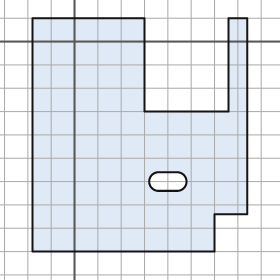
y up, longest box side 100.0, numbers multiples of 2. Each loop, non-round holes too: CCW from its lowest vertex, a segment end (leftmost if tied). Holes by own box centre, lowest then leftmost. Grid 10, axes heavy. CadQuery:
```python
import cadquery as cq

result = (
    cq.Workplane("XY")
    .moveTo(-18.0, -90.0)
    .lineTo(60.0, -90.0)
    .lineTo(60.0, -74.0)
    .lineTo(74.0, -74.0)
    .lineTo(74.0, 10.0)
    .lineTo(66.0, 10.0)
    .lineTo(66.0, -30.0)
    .lineTo(30.0, -30.0)
    .lineTo(30.0, 10.0)
    .lineTo(-18.0, 10.0)
    .close()
    .moveTo(36.0, -64.0)
    .lineTo(44.0, -64.0)
    .threePointArc((48.0, -60.0), (44.0, -56.0))
    .lineTo(36.0, -56.0)
    .threePointArc((32.0, -60.0), (36.0, -64.0))
    .close()
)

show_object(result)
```